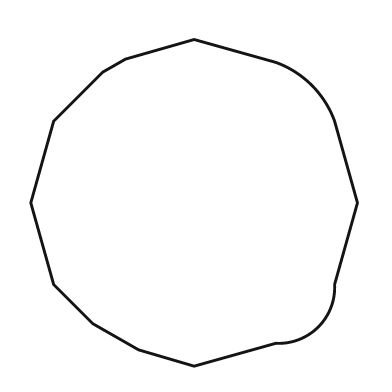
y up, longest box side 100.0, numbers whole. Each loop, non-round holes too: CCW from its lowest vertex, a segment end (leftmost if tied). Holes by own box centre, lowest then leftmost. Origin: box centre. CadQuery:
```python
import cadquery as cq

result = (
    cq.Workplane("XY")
    .moveTo(0.0, -50.0)
    .lineTo(25.0, -43.0)
    .threePointArc((38.0, -38.0), (43.0, -25.0))
    .lineTo(50.0, 0.0)
    .lineTo(43.0, 25.0)
    .threePointArc((36.0, 36.0), (25.0, 43.0))
    .lineTo(0.0, 50.0)
    .lineTo(-21.0, 44.0)
    .lineTo(-28.0, 40.0)
    .lineTo(-43.0, 25.0)
    .lineTo(-50.0, 0.0)
    .lineTo(-43.0, -25.0)
    .lineTo(-31.0, -37.0)
    .lineTo(-17.0, -45.0)
    .close()
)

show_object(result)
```